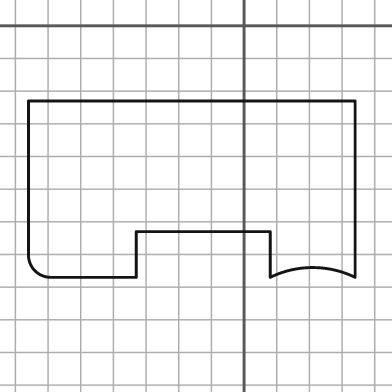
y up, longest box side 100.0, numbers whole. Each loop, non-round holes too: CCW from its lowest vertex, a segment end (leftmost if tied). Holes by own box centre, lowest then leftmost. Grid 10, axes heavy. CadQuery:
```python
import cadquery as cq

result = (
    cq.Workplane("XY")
    .moveTo(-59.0, -77.0)
    .lineTo(-33.0, -77.0)
    .lineTo(-33.0, -63.0)
    .lineTo(8.0, -63.0)
    .lineTo(8.0, -77.0)
    .threePointArc((21.0, -74.0), (34.0, -77.0))
    .lineTo(34.0, -23.0)
    .lineTo(-66.0, -23.0)
    .lineTo(-66.0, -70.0)
    .threePointArc((-64.0, -75.0), (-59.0, -77.0))
    .close()
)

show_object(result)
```